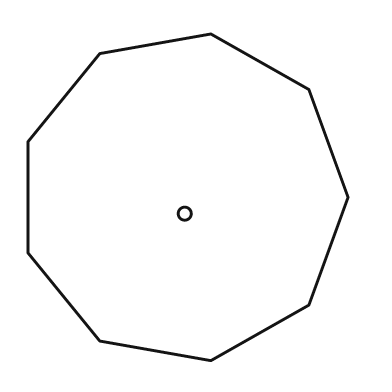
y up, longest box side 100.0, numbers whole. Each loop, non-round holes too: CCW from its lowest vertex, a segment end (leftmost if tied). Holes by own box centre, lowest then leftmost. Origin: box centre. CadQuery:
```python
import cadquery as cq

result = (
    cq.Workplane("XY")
    .moveTo(7.0, -50.0)
    .lineTo(37.0, -33.0)
    .lineTo(49.0, 0.0)
    .lineTo(37.0, 33.0)
    .lineTo(7.0, 50.0)
    .lineTo(-27.0, 44.0)
    .lineTo(-49.0, 17.0)
    .lineTo(-49.0, -17.0)
    .lineTo(-27.0, -44.0)
    .close()
    .moveTo(-1.0, -5.0)
    .circle(2.0)
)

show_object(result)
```